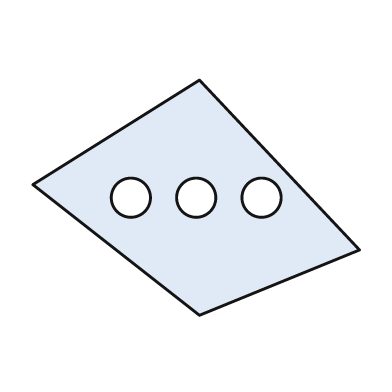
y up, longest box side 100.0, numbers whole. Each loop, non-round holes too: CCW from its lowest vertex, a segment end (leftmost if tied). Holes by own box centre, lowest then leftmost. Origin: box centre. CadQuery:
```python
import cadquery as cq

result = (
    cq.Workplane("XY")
    .moveTo(1.0, -36.0)
    .lineTo(50.0, -16.0)
    .lineTo(1.0, 36.0)
    .lineTo(-50.0, 4.0)
    .close()
    .moveTo(-20.0, 0.0)
    .circle(6.0)
    .moveTo(0.0, 0.0)
    .circle(6.0)
    .moveTo(20.0, 0.0)
    .circle(6.0)
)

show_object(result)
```